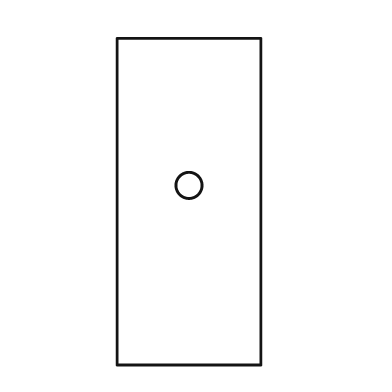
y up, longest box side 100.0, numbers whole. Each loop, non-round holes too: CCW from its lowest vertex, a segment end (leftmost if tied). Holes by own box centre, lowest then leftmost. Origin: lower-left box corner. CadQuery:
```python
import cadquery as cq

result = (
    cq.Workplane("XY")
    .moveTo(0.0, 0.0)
    .lineTo(44.0, 0.0)
    .lineTo(44.0, 100.0)
    .lineTo(0.0, 100.0)
    .close()
    .moveTo(22.0, 55.0)
    .circle(4.0)
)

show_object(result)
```